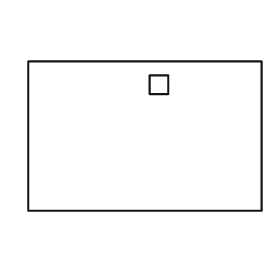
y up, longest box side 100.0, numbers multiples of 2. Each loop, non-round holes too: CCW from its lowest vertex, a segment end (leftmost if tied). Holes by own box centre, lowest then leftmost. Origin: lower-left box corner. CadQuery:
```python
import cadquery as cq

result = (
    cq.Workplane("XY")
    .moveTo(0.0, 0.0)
    .lineTo(100.0, 0.0)
    .lineTo(100.0, 64.0)
    .lineTo(0.0, 64.0)
    .close()
    .moveTo(52.0, 50.0)
    .lineTo(60.0, 50.0)
    .lineTo(60.0, 58.0)
    .lineTo(52.0, 58.0)
    .close()
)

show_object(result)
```